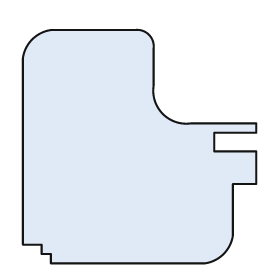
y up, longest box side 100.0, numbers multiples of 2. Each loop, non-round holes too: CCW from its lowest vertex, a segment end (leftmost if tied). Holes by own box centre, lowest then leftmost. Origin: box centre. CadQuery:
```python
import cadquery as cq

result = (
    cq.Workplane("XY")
    .moveTo(-38.0, -50.0)
    .lineTo(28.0, -50.0)
    .threePointArc((36.0, -46.0), (40.0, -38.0))
    .lineTo(40.0, -16.0)
    .lineTo(50.0, -16.0)
    .lineTo(50.0, -2.0)
    .lineTo(32.0, -2.0)
    .lineTo(32.0, 6.0)
    .lineTo(50.0, 6.0)
    .lineTo(50.0, 10.0)
    .lineTo(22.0, 10.0)
    .threePointArc((10.0, 14.0), (6.0, 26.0))
    .lineTo(6.0, 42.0)
    .threePointArc((4.0, 48.0), (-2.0, 50.0))
    .lineTo(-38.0, 50.0)
    .threePointArc((-46.0, 46.0), (-50.0, 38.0))
    .lineTo(-50.0, -42.0)
    .lineTo(-42.0, -42.0)
    .lineTo(-42.0, -46.0)
    .lineTo(-38.0, -46.0)
    .close()
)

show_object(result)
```